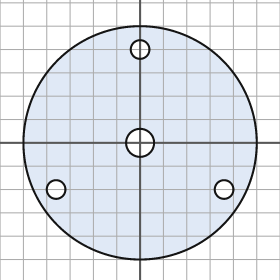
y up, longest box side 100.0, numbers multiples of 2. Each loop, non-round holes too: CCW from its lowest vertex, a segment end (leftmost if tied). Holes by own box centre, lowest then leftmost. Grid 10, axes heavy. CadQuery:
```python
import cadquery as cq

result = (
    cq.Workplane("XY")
    .moveTo(0.0, 0.0)
    .circle(50.0)
    .moveTo(-36.0, -20.0)
    .circle(4.0)
    .moveTo(36.0, -20.0)
    .circle(4.0)
    .moveTo(0.0, 0.0)
    .circle(6.0)
    .moveTo(0.0, 40.0)
    .circle(4.0)
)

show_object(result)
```